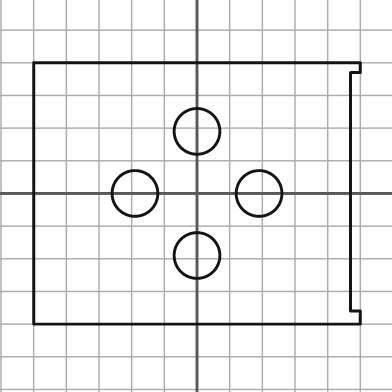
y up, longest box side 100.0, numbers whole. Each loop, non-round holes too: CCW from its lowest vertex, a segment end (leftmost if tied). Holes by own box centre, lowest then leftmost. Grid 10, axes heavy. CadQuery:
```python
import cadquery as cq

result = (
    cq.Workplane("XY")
    .moveTo(-50.0, -40.0)
    .lineTo(50.0, -40.0)
    .lineTo(50.0, -36.0)
    .lineTo(47.0, -36.0)
    .lineTo(47.0, 37.0)
    .lineTo(50.0, 37.0)
    .lineTo(50.0, 40.0)
    .lineTo(-50.0, 40.0)
    .close()
    .moveTo(0.0, -19.0)
    .circle(7.0)
    .moveTo(-19.0, 0.0)
    .circle(7.0)
    .moveTo(19.0, 0.0)
    .circle(7.0)
    .moveTo(0.0, 19.0)
    .circle(7.0)
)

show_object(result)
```